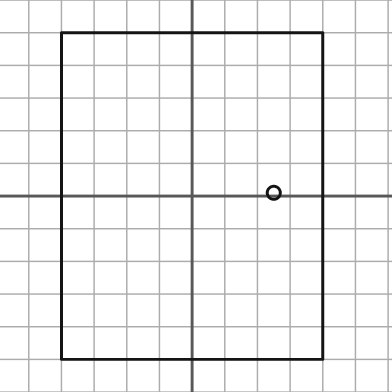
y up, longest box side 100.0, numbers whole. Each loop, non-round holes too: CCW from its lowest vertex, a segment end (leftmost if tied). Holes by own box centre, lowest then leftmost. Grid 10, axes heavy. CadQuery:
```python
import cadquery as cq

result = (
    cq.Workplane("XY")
    .moveTo(-40.0, -50.0)
    .lineTo(40.0, -50.0)
    .lineTo(40.0, 50.0)
    .lineTo(-40.0, 50.0)
    .close()
    .moveTo(25.0, 1.0)
    .circle(2.0)
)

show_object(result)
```